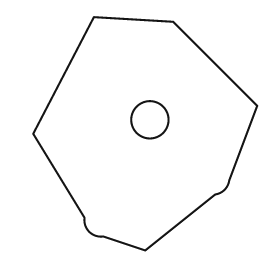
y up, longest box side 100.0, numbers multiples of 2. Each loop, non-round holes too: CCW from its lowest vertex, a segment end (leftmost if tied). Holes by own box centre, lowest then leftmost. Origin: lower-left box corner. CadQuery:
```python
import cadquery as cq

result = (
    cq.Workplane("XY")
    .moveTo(48.0, 0.0)
    .lineTo(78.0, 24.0)
    .threePointArc((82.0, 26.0), (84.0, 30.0))
    .lineTo(96.0, 62.0)
    .lineTo(60.0, 98.0)
    .lineTo(26.0, 100.0)
    .lineTo(0.0, 50.0)
    .lineTo(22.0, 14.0)
    .threePointArc((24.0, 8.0), (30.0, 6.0))
    .close()
    .moveTo(50.0, 56.0)
    .circle(8.0)
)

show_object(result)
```